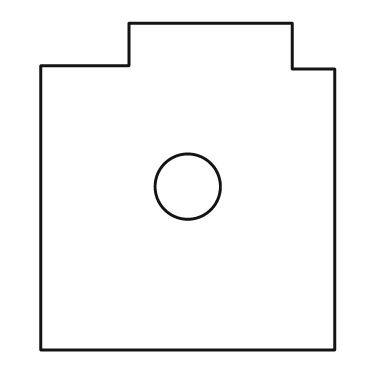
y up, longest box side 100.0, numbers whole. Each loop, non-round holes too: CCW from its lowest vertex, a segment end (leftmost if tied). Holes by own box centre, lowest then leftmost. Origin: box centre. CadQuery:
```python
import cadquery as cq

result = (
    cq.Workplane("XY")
    .moveTo(-45.0, -50.0)
    .lineTo(45.0, -50.0)
    .lineTo(45.0, 36.0)
    .lineTo(32.0, 36.0)
    .lineTo(32.0, 50.0)
    .lineTo(-18.0, 50.0)
    .lineTo(-18.0, 37.0)
    .lineTo(-45.0, 37.0)
    .close()
    .moveTo(0.0, 0.0)
    .circle(10.0)
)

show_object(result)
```